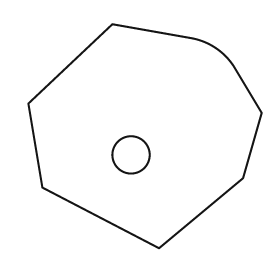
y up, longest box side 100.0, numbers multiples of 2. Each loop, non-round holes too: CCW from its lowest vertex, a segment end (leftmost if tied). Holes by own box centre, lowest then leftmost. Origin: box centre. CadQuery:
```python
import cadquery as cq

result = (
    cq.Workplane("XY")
    .moveTo(6.0, -48.0)
    .lineTo(42.0, -18.0)
    .lineTo(50.0, 10.0)
    .lineTo(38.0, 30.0)
    .threePointArc((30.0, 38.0), (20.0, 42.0))
    .lineTo(-14.0, 48.0)
    .lineTo(-50.0, 14.0)
    .lineTo(-44.0, -22.0)
    .close()
    .moveTo(-6.0, -8.0)
    .circle(8.0)
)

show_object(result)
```